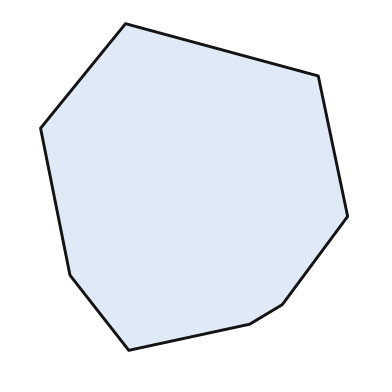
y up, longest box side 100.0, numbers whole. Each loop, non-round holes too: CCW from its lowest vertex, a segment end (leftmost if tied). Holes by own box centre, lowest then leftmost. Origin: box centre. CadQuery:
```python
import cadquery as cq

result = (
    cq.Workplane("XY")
    .moveTo(-20.0, -50.0)
    .lineTo(17.0, -42.0)
    .lineTo(27.0, -36.0)
    .lineTo(47.0, -9.0)
    .lineTo(38.0, 34.0)
    .lineTo(-21.0, 50.0)
    .lineTo(-47.0, 18.0)
    .lineTo(-38.0, -27.0)
    .close()
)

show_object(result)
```